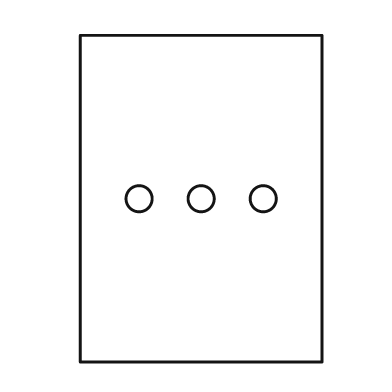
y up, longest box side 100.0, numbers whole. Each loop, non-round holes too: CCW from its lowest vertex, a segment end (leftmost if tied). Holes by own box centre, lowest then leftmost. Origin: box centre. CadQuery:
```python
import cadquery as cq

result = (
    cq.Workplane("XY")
    .moveTo(-37.0, -50.0)
    .lineTo(37.0, -50.0)
    .lineTo(37.0, 50.0)
    .lineTo(-37.0, 50.0)
    .close()
    .moveTo(-19.0, 0.0)
    .circle(4.0)
    .moveTo(0.0, 0.0)
    .circle(4.0)
    .moveTo(19.0, 0.0)
    .circle(4.0)
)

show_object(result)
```